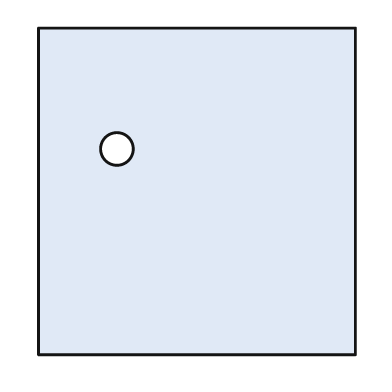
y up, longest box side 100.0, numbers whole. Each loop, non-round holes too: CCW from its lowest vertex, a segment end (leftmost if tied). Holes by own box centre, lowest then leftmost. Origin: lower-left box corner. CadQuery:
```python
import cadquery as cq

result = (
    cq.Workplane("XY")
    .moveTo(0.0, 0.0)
    .lineTo(97.0, 0.0)
    .lineTo(97.0, 100.0)
    .lineTo(0.0, 100.0)
    .close()
    .moveTo(24.0, 63.0)
    .circle(5.0)
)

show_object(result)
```